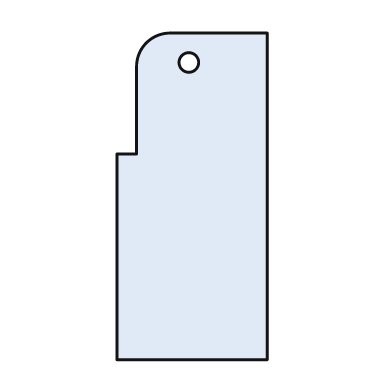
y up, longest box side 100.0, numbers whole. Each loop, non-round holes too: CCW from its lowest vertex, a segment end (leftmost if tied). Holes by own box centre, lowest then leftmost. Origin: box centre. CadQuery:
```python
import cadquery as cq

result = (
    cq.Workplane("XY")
    .moveTo(-23.0, -50.0)
    .lineTo(23.0, -50.0)
    .lineTo(23.0, 50.0)
    .lineTo(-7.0, 50.0)
    .threePointArc((-14.0, 47.0), (-17.0, 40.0))
    .lineTo(-17.0, 13.0)
    .lineTo(-23.0, 13.0)
    .close()
    .moveTo(-1.0, 41.0)
    .circle(3.0)
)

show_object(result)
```